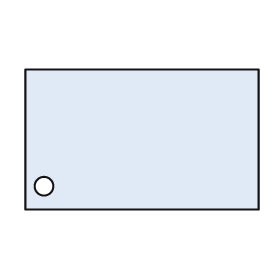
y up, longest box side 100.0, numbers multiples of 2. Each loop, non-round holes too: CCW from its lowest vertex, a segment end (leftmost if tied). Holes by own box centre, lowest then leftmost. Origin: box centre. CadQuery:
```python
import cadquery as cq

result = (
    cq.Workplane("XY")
    .moveTo(-50.0, -30.0)
    .lineTo(50.0, -30.0)
    .lineTo(50.0, 30.0)
    .lineTo(-50.0, 30.0)
    .close()
    .moveTo(-42.0, -20.0)
    .circle(4.0)
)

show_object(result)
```